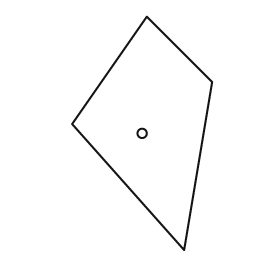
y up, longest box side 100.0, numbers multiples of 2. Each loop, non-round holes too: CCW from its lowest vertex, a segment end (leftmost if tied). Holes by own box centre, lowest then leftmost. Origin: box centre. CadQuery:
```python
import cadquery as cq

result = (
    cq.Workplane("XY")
    .moveTo(18.0, -50.0)
    .lineTo(30.0, 22.0)
    .lineTo(2.0, 50.0)
    .lineTo(-30.0, 4.0)
    .close()
    .moveTo(0.0, 0.0)
    .circle(2.0)
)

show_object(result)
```